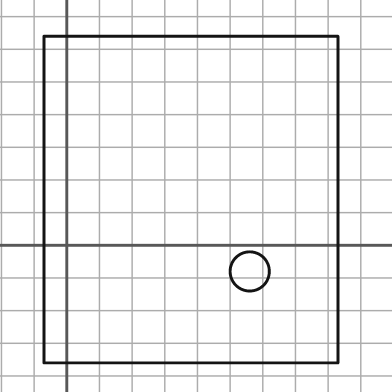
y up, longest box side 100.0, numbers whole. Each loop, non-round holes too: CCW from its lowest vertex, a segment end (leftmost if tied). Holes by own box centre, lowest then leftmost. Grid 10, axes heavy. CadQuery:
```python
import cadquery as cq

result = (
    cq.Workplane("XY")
    .moveTo(-7.0, -36.0)
    .lineTo(83.0, -36.0)
    .lineTo(83.0, 64.0)
    .lineTo(-7.0, 64.0)
    .close()
    .moveTo(56.0, -8.0)
    .circle(6.0)
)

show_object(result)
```